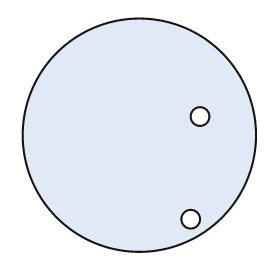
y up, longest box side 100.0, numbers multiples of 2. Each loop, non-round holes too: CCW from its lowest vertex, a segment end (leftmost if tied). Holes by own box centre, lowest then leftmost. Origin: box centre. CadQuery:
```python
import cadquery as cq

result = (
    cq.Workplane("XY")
    .moveTo(0.0, 0.0)
    .circle(50.0)
    .moveTo(22.0, -36.0)
    .circle(4.0)
    .moveTo(26.0, 8.0)
    .circle(4.0)
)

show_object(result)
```